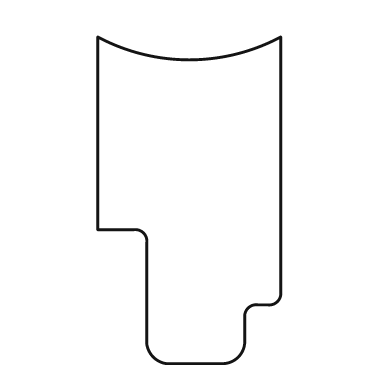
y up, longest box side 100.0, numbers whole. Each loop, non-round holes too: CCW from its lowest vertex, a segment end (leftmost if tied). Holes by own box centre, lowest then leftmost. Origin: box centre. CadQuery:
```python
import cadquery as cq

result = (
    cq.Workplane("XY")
    .moveTo(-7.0, -50.0)
    .lineTo(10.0, -50.0)
    .threePointArc((15.0, -48.0), (17.0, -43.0))
    .lineTo(17.0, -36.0)
    .threePointArc((18.0, -33.0), (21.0, -32.0))
    .lineTo(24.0, -32.0)
    .threePointArc((27.0, -31.0), (28.0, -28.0))
    .lineTo(28.0, 50.0)
    .threePointArc((0.0, 43.0), (-28.0, 50.0))
    .lineTo(-28.0, -9.0)
    .lineTo(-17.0, -9.0)
    .threePointArc((-14.0, -10.0), (-13.0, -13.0))
    .lineTo(-13.0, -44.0)
    .threePointArc((-11.0, -48.0), (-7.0, -50.0))
    .close()
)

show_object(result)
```